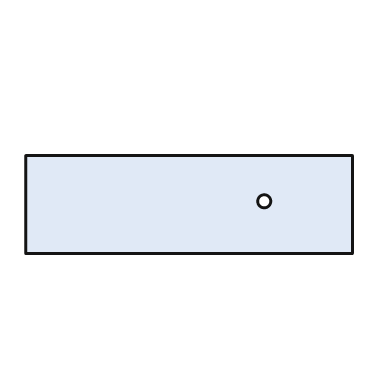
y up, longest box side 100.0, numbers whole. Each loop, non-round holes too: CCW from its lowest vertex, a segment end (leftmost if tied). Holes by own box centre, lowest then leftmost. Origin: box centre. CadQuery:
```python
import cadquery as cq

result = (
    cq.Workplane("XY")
    .moveTo(-50.0, -15.0)
    .lineTo(50.0, -15.0)
    .lineTo(50.0, 15.0)
    .lineTo(-50.0, 15.0)
    .close()
    .moveTo(23.0, 1.0)
    .circle(2.0)
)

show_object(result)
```